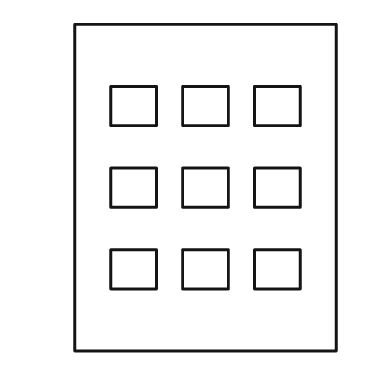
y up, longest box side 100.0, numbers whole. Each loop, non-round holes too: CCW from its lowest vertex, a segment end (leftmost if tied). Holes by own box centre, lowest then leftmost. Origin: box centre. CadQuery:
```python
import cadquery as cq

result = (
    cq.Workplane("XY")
    .moveTo(-40.0, -50.0)
    .lineTo(40.0, -50.0)
    .lineTo(40.0, 50.0)
    .lineTo(-40.0, 50.0)
    .close()
    .moveTo(-29.0, -31.0)
    .lineTo(-15.0, -31.0)
    .lineTo(-15.0, -19.0)
    .lineTo(-29.0, -19.0)
    .close()
    .moveTo(-7.0, -31.0)
    .lineTo(7.0, -31.0)
    .lineTo(7.0, -19.0)
    .lineTo(-7.0, -19.0)
    .close()
    .moveTo(15.0, -31.0)
    .lineTo(29.0, -31.0)
    .lineTo(29.0, -19.0)
    .lineTo(15.0, -19.0)
    .close()
    .moveTo(-29.0, -6.0)
    .lineTo(-15.0, -6.0)
    .lineTo(-15.0, 6.0)
    .lineTo(-29.0, 6.0)
    .close()
    .moveTo(-7.0, -6.0)
    .lineTo(7.0, -6.0)
    .lineTo(7.0, 6.0)
    .lineTo(-7.0, 6.0)
    .close()
    .moveTo(15.0, -6.0)
    .lineTo(29.0, -6.0)
    .lineTo(29.0, 6.0)
    .lineTo(15.0, 6.0)
    .close()
    .moveTo(-29.0, 19.0)
    .lineTo(-15.0, 19.0)
    .lineTo(-15.0, 31.0)
    .lineTo(-29.0, 31.0)
    .close()
    .moveTo(-7.0, 19.0)
    .lineTo(7.0, 19.0)
    .lineTo(7.0, 31.0)
    .lineTo(-7.0, 31.0)
    .close()
    .moveTo(15.0, 19.0)
    .lineTo(29.0, 19.0)
    .lineTo(29.0, 31.0)
    .lineTo(15.0, 31.0)
    .close()
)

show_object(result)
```